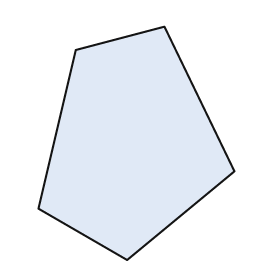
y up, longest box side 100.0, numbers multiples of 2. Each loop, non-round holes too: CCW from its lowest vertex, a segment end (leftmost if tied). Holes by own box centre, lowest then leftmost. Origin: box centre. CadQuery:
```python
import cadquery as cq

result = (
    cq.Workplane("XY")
    .moveTo(-4.0, -50.0)
    .lineTo(42.0, -12.0)
    .lineTo(12.0, 50.0)
    .lineTo(-26.0, 40.0)
    .lineTo(-42.0, -28.0)
    .close()
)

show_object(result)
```